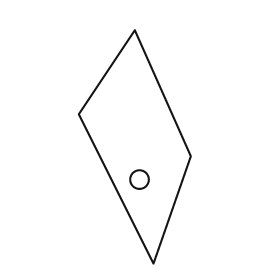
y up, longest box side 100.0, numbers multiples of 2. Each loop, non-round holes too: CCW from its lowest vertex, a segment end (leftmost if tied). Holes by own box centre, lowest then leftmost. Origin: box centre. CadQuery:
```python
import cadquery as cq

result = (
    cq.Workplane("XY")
    .moveTo(8.0, -50.0)
    .lineTo(24.0, -4.0)
    .lineTo(0.0, 50.0)
    .lineTo(-24.0, 14.0)
    .close()
    .moveTo(2.0, -14.0)
    .circle(4.0)
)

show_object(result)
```